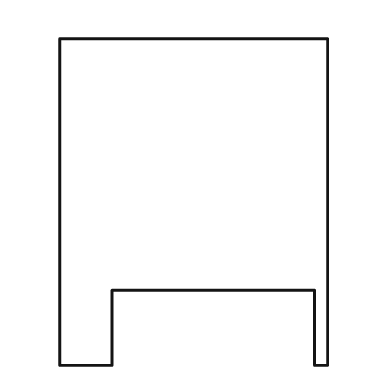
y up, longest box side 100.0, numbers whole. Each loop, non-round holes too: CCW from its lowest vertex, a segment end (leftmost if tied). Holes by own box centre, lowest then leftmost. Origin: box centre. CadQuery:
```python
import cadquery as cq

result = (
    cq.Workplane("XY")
    .moveTo(-41.0, -50.0)
    .lineTo(-25.0, -50.0)
    .lineTo(-25.0, -27.0)
    .lineTo(37.0, -27.0)
    .lineTo(37.0, -50.0)
    .lineTo(41.0, -50.0)
    .lineTo(41.0, 50.0)
    .lineTo(-41.0, 50.0)
    .close()
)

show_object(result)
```